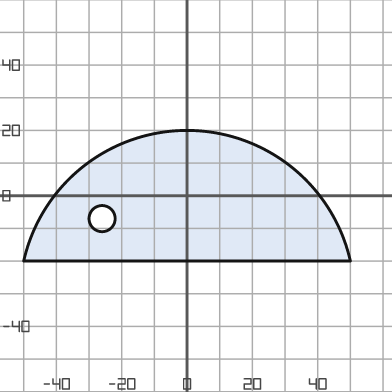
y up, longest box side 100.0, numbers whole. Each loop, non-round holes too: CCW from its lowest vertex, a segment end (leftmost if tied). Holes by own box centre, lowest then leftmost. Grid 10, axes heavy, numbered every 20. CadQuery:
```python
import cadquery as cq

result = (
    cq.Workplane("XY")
    .moveTo(-50.0, -20.0)
    .lineTo(50.0, -20.0)
    .threePointArc((0.0, 20.0), (-50.0, -20.0))
    .close()
    .moveTo(-26.0, -7.0)
    .circle(4.0)
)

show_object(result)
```